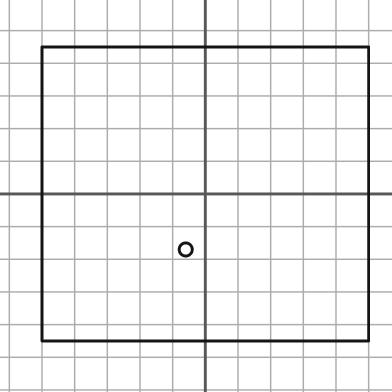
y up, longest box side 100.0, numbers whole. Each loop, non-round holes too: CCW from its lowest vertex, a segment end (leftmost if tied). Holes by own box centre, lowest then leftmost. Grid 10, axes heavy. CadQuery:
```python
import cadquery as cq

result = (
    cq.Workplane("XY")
    .moveTo(-50.0, -45.0)
    .lineTo(50.0, -45.0)
    .lineTo(50.0, 45.0)
    .lineTo(-50.0, 45.0)
    .close()
    .moveTo(-6.0, -17.0)
    .circle(2.0)
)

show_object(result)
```